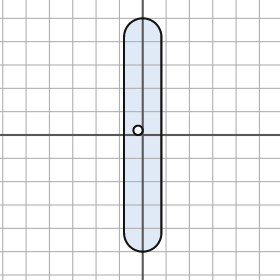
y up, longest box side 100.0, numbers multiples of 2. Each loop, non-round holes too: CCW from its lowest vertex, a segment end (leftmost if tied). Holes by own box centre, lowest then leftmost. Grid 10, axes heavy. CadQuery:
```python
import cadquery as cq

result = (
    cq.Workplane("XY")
    .moveTo(-8.0, -42.0)
    .threePointArc((0.0, -50.0), (8.0, -42.0))
    .lineTo(8.0, 42.0)
    .threePointArc((0.0, 50.0), (-8.0, 42.0))
    .close()
    .moveTo(-2.0, 2.0)
    .circle(2.0)
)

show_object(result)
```